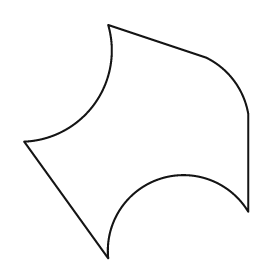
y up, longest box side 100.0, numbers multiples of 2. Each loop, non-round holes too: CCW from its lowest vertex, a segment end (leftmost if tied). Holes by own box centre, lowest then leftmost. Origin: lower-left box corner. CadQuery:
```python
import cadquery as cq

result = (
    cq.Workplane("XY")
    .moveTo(36.0, 0.0)
    .threePointArc((58.0, 34.0), (96.0, 20.0))
    .lineTo(96.0, 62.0)
    .threePointArc((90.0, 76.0), (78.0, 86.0))
    .lineTo(36.0, 100.0)
    .threePointArc((30.0, 66.0), (0.0, 50.0))
    .close()
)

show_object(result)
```